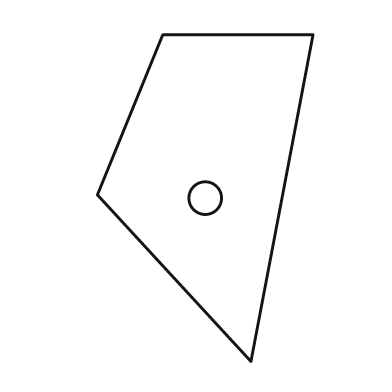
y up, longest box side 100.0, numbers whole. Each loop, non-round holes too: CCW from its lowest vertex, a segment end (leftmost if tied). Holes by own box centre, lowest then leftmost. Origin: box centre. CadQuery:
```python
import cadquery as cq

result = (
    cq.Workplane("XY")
    .moveTo(14.0, -50.0)
    .lineTo(33.0, 50.0)
    .lineTo(-13.0, 50.0)
    .lineTo(-33.0, 1.0)
    .close()
    .moveTo(0.0, 0.0)
    .circle(5.0)
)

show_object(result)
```